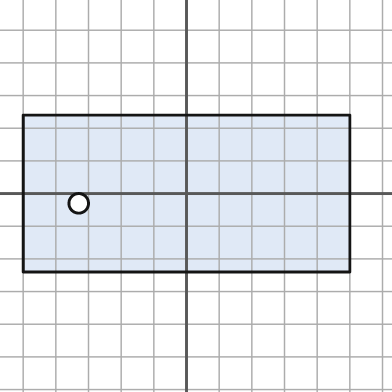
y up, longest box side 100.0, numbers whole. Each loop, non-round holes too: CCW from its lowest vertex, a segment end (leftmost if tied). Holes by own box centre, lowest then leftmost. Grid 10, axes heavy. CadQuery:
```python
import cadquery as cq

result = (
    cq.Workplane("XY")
    .moveTo(-50.0, -24.0)
    .lineTo(50.0, -24.0)
    .lineTo(50.0, 24.0)
    .lineTo(-50.0, 24.0)
    .close()
    .moveTo(-33.0, -3.0)
    .circle(3.0)
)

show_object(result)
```